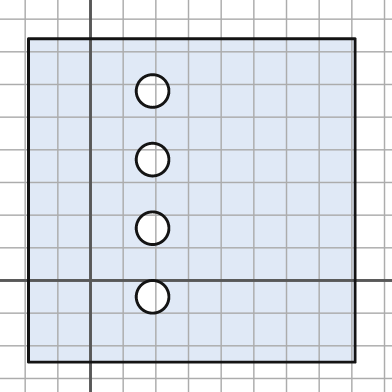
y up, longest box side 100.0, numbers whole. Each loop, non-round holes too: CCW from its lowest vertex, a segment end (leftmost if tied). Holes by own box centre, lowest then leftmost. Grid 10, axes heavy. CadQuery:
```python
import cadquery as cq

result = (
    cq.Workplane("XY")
    .moveTo(-19.0, -25.0)
    .lineTo(81.0, -25.0)
    .lineTo(81.0, 74.0)
    .lineTo(-19.0, 74.0)
    .close()
    .moveTo(19.0, -5.0)
    .circle(5.0)
    .moveTo(19.0, 16.0)
    .circle(5.0)
    .moveTo(19.0, 37.0)
    .circle(5.0)
    .moveTo(19.0, 58.0)
    .circle(5.0)
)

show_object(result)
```